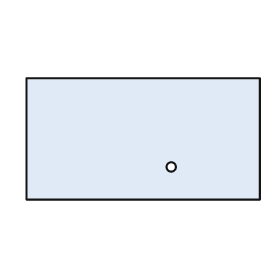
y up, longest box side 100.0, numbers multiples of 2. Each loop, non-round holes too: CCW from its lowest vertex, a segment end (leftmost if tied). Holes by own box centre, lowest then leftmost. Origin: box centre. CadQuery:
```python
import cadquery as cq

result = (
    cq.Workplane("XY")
    .moveTo(-50.0, -26.0)
    .lineTo(50.0, -26.0)
    .lineTo(50.0, 26.0)
    .lineTo(-50.0, 26.0)
    .close()
    .moveTo(12.0, -12.0)
    .circle(2.0)
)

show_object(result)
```